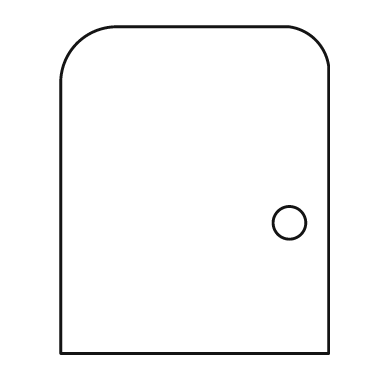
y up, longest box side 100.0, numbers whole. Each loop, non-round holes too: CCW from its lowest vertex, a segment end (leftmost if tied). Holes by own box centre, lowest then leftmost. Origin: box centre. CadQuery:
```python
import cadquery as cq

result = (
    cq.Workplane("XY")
    .moveTo(-41.0, -50.0)
    .lineTo(41.0, -50.0)
    .lineTo(41.0, 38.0)
    .threePointArc((37.0, 46.0), (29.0, 50.0))
    .lineTo(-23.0, 50.0)
    .threePointArc((-36.0, 45.0), (-41.0, 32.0))
    .close()
    .moveTo(29.0, -10.0)
    .circle(5.0)
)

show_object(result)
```